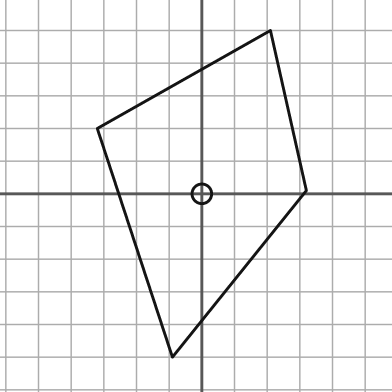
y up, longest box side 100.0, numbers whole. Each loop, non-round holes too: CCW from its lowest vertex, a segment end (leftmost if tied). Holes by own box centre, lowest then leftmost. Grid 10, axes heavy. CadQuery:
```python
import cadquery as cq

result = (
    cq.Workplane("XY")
    .moveTo(-9.0, -50.0)
    .lineTo(32.0, 1.0)
    .lineTo(21.0, 50.0)
    .lineTo(-32.0, 20.0)
    .close()
    .moveTo(0.0, 0.0)
    .circle(3.0)
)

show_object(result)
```